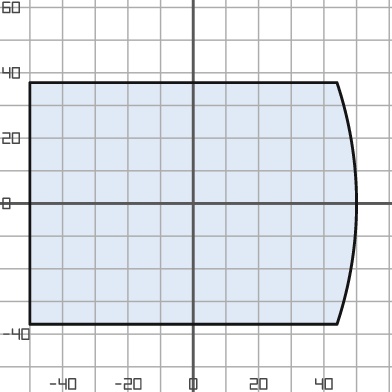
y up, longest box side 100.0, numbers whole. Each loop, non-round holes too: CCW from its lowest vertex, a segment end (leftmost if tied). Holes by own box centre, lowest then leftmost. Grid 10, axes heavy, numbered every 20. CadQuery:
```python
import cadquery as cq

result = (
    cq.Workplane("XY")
    .moveTo(-50.0, -37.0)
    .lineTo(44.0, -37.0)
    .threePointArc((50.0, 0.0), (44.0, 37.0))
    .lineTo(-50.0, 37.0)
    .close()
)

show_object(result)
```